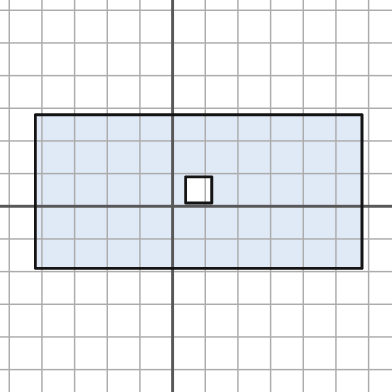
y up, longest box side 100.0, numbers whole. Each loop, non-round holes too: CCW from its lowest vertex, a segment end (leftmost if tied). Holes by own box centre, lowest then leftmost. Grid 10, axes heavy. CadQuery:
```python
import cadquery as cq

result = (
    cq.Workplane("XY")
    .moveTo(-42.0, -19.0)
    .lineTo(58.0, -19.0)
    .lineTo(58.0, 28.0)
    .lineTo(-42.0, 28.0)
    .close()
    .moveTo(4.0, 1.0)
    .lineTo(12.0, 1.0)
    .lineTo(12.0, 9.0)
    .lineTo(4.0, 9.0)
    .close()
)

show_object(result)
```